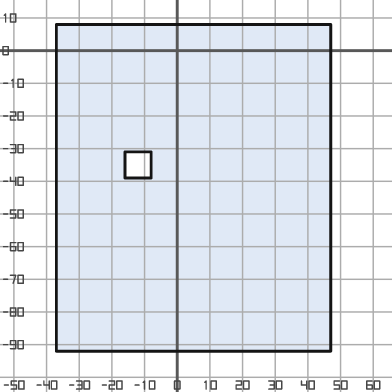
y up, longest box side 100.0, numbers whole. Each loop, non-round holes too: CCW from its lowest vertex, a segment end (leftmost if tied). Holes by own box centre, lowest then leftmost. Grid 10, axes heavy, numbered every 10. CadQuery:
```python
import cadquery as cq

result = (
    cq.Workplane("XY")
    .moveTo(-37.0, -92.0)
    .lineTo(47.0, -92.0)
    .lineTo(47.0, 8.0)
    .lineTo(-37.0, 8.0)
    .close()
    .moveTo(-16.0, -39.0)
    .lineTo(-8.0, -39.0)
    .lineTo(-8.0, -31.0)
    .lineTo(-16.0, -31.0)
    .close()
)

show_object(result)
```